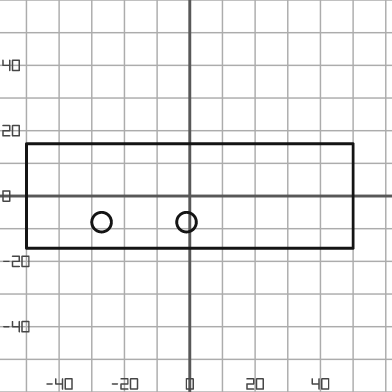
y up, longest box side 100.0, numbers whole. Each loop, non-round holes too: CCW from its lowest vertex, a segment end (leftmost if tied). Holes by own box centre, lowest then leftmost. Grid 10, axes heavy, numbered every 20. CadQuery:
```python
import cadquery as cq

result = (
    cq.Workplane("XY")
    .moveTo(-50.0, -16.0)
    .lineTo(50.0, -16.0)
    .lineTo(50.0, 16.0)
    .lineTo(-50.0, 16.0)
    .close()
    .moveTo(-27.0, -8.0)
    .circle(3.0)
    .moveTo(-1.0, -8.0)
    .circle(3.0)
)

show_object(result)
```